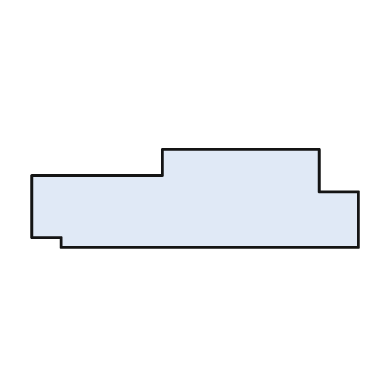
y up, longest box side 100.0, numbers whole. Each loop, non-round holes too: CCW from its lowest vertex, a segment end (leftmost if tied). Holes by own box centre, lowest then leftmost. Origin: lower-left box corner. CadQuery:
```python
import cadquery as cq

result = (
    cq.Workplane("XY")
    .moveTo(9.0, 0.0)
    .lineTo(100.0, 0.0)
    .lineTo(100.0, 17.0)
    .lineTo(88.0, 17.0)
    .lineTo(88.0, 30.0)
    .lineTo(40.0, 30.0)
    .lineTo(40.0, 22.0)
    .lineTo(0.0, 22.0)
    .lineTo(0.0, 3.0)
    .lineTo(9.0, 3.0)
    .close()
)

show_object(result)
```